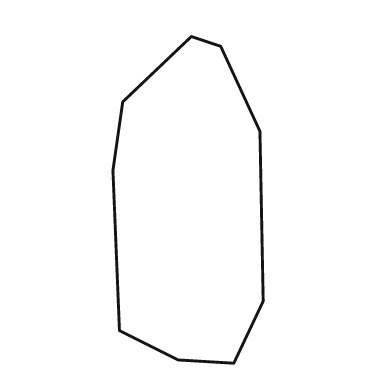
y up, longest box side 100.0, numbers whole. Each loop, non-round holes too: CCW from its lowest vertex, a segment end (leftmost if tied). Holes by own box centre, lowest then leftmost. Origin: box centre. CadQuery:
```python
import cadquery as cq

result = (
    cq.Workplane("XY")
    .moveTo(14.0, -50.0)
    .lineTo(23.0, -31.0)
    .lineTo(22.0, 21.0)
    .lineTo(10.0, 47.0)
    .lineTo(1.0, 50.0)
    .lineTo(-20.0, 30.0)
    .lineTo(-23.0, 9.0)
    .lineTo(-21.0, -40.0)
    .lineTo(-3.0, -49.0)
    .close()
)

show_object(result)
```